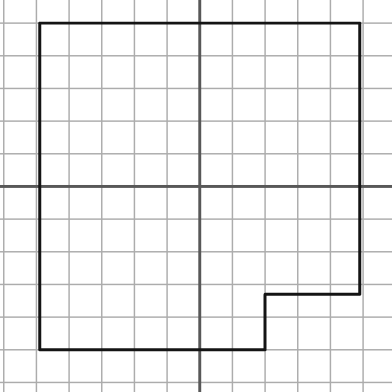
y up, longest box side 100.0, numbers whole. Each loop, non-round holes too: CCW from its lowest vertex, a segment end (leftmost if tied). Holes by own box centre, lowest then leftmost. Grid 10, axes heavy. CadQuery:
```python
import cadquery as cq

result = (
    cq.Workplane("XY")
    .moveTo(-49.0, -50.0)
    .lineTo(20.0, -50.0)
    .lineTo(20.0, -33.0)
    .lineTo(49.0, -33.0)
    .lineTo(49.0, 50.0)
    .lineTo(-49.0, 50.0)
    .close()
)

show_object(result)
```